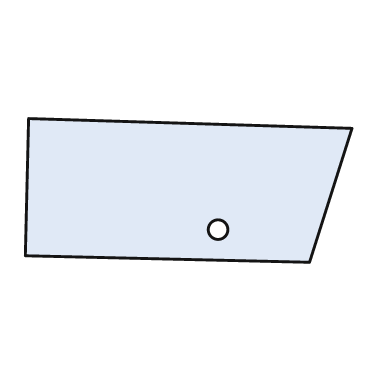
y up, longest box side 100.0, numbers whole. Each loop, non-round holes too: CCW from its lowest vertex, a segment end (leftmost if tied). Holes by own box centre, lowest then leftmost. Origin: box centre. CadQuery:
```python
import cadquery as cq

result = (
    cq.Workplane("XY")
    .moveTo(37.0, -22.0)
    .lineTo(50.0, 19.0)
    .lineTo(-49.0, 22.0)
    .lineTo(-50.0, -20.0)
    .close()
    .moveTo(9.0, -12.0)
    .circle(3.0)
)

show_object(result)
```